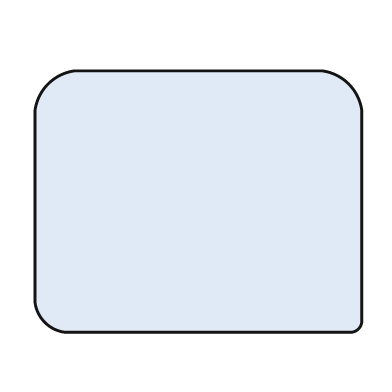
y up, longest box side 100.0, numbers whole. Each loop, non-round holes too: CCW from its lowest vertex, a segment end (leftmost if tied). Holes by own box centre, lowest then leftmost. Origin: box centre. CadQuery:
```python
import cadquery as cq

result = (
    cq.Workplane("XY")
    .moveTo(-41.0, -40.0)
    .lineTo(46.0, -40.0)
    .threePointArc((49.0, -39.0), (50.0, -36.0))
    .lineTo(50.0, 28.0)
    .threePointArc((46.0, 36.0), (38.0, 40.0))
    .lineTo(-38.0, 40.0)
    .threePointArc((-46.0, 36.0), (-50.0, 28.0))
    .lineTo(-50.0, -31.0)
    .threePointArc((-47.0, -37.0), (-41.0, -40.0))
    .close()
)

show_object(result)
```